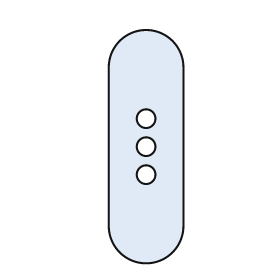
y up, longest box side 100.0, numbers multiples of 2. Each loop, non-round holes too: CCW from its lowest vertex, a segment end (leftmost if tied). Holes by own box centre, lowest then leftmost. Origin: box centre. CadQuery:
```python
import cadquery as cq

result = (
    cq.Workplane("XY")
    .moveTo(-16.0, -34.0)
    .threePointArc((0.0, -50.0), (16.0, -34.0))
    .lineTo(16.0, 34.0)
    .threePointArc((0.0, 50.0), (-16.0, 34.0))
    .close()
    .moveTo(0.0, -12.0)
    .circle(4.0)
    .moveTo(0.0, 0.0)
    .circle(4.0)
    .moveTo(0.0, 12.0)
    .circle(4.0)
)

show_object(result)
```